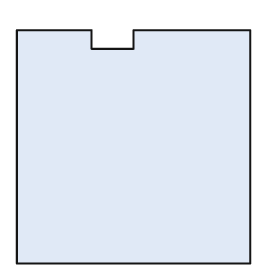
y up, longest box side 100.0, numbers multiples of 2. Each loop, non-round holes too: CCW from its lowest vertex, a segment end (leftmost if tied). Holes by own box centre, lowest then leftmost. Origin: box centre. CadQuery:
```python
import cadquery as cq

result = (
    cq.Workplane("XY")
    .moveTo(-50.0, -50.0)
    .lineTo(50.0, -50.0)
    .lineTo(50.0, 50.0)
    .lineTo(0.0, 50.0)
    .lineTo(0.0, 42.0)
    .lineTo(-18.0, 42.0)
    .lineTo(-18.0, 50.0)
    .lineTo(-50.0, 50.0)
    .close()
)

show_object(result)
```